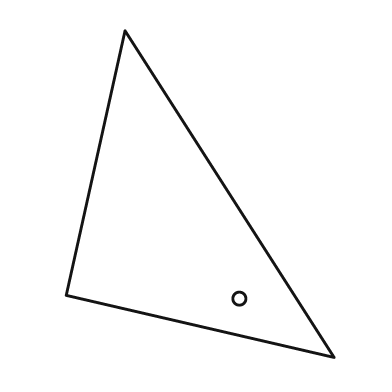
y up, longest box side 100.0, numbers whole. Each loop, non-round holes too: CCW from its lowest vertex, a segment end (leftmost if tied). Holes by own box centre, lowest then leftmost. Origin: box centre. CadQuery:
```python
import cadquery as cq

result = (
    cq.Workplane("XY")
    .moveTo(41.0, -50.0)
    .lineTo(-23.0, 50.0)
    .lineTo(-41.0, -31.0)
    .close()
    .moveTo(12.0, -32.0)
    .circle(2.0)
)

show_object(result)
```